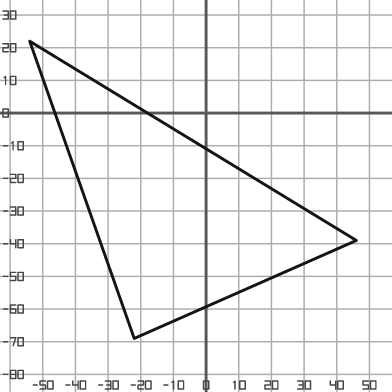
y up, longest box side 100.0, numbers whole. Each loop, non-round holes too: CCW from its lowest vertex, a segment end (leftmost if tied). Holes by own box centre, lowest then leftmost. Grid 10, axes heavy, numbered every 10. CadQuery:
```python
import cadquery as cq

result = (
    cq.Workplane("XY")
    .moveTo(-22.0, -69.0)
    .lineTo(46.0, -39.0)
    .lineTo(-54.0, 22.0)
    .close()
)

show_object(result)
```